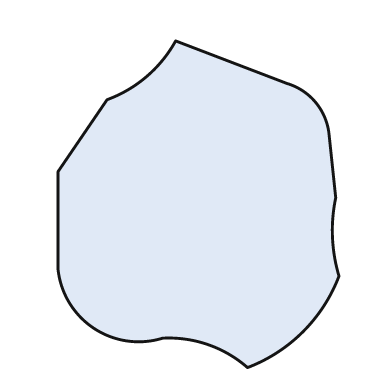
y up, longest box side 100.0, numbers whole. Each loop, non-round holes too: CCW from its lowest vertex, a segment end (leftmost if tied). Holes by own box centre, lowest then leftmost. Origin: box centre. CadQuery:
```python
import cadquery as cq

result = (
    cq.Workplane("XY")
    .moveTo(15.0, -50.0)
    .threePointArc((32.0, -39.0), (43.0, -22.0))
    .threePointArc((41.0, -10.0), (42.0, 2.0))
    .lineTo(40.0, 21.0)
    .threePointArc((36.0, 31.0), (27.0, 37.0))
    .lineTo(-7.0, 50.0)
    .threePointArc((-16.0, 39.0), (-28.0, 32.0))
    .lineTo(-43.0, 10.0)
    .lineTo(-43.0, -20.0)
    .threePointArc((-32.0, -38.0), (-11.0, -41.0))
    .threePointArc((3.0, -43.0), (15.0, -50.0))
    .close()
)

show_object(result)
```